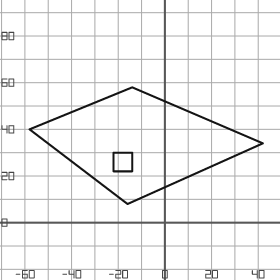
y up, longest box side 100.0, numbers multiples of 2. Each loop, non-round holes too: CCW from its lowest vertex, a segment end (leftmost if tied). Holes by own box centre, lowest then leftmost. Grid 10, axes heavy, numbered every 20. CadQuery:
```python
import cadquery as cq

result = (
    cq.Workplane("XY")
    .moveTo(-16.0, 8.0)
    .lineTo(42.0, 34.0)
    .lineTo(-14.0, 58.0)
    .lineTo(-58.0, 40.0)
    .close()
    .moveTo(-22.0, 22.0)
    .lineTo(-14.0, 22.0)
    .lineTo(-14.0, 30.0)
    .lineTo(-22.0, 30.0)
    .close()
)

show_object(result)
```